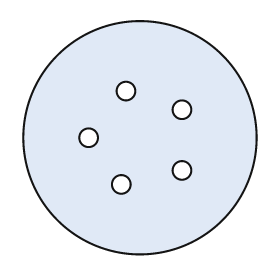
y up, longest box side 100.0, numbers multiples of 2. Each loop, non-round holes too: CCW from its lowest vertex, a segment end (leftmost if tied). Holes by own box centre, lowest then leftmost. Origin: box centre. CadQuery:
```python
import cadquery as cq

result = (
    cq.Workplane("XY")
    .moveTo(0.0, 0.0)
    .circle(50.0)
    .moveTo(-8.0, -20.0)
    .circle(4.0)
    .moveTo(18.0, -14.0)
    .circle(4.0)
    .moveTo(-22.0, 0.0)
    .circle(4.0)
    .moveTo(18.0, 12.0)
    .circle(4.0)
    .moveTo(-6.0, 20.0)
    .circle(4.0)
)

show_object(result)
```